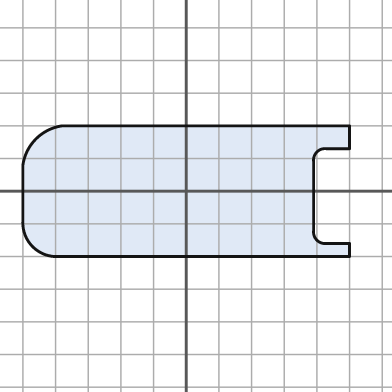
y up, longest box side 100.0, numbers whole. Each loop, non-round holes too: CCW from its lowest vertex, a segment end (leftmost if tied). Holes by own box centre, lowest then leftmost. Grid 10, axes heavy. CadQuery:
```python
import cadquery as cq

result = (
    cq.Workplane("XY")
    .moveTo(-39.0, -20.0)
    .lineTo(50.0, -20.0)
    .lineTo(50.0, -16.0)
    .lineTo(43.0, -16.0)
    .threePointArc((40.0, -15.0), (39.0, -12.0))
    .lineTo(39.0, 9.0)
    .threePointArc((40.0, 12.0), (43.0, 13.0))
    .lineTo(50.0, 13.0)
    .lineTo(50.0, 20.0)
    .lineTo(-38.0, 20.0)
    .threePointArc((-46.0, 16.0), (-50.0, 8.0))
    .lineTo(-50.0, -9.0)
    .threePointArc((-47.0, -17.0), (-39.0, -20.0))
    .close()
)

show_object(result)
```